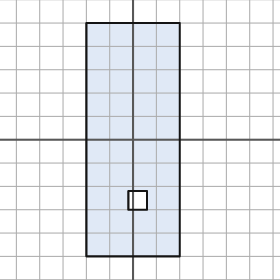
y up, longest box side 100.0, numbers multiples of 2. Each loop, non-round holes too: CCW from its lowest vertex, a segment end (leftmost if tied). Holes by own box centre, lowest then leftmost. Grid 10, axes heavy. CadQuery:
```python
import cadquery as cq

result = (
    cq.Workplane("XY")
    .moveTo(-20.0, -50.0)
    .lineTo(20.0, -50.0)
    .lineTo(20.0, 50.0)
    .lineTo(-20.0, 50.0)
    .close()
    .moveTo(-2.0, -30.0)
    .lineTo(6.0, -30.0)
    .lineTo(6.0, -22.0)
    .lineTo(-2.0, -22.0)
    .close()
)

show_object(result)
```